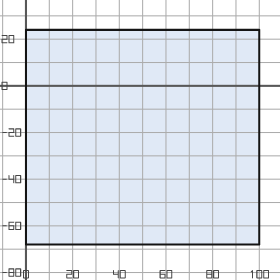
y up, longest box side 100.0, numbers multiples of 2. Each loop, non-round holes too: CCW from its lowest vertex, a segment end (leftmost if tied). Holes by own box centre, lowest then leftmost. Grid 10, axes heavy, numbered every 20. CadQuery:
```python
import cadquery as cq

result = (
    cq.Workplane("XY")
    .moveTo(0.0, -68.0)
    .lineTo(100.0, -68.0)
    .lineTo(100.0, 24.0)
    .lineTo(0.0, 24.0)
    .close()
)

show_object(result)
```